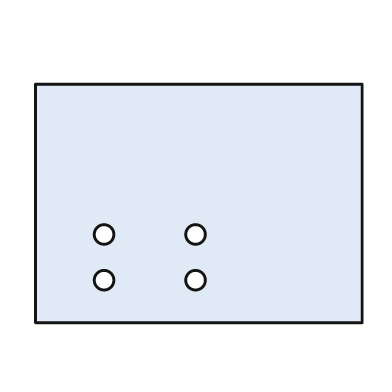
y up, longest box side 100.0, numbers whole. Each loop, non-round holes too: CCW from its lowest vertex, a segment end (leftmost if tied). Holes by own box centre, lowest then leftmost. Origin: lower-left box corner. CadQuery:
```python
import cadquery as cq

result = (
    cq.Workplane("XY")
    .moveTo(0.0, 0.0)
    .lineTo(100.0, 0.0)
    .lineTo(100.0, 73.0)
    .lineTo(0.0, 73.0)
    .close()
    .moveTo(21.0, 13.0)
    .circle(3.0)
    .moveTo(49.0, 13.0)
    .circle(3.0)
    .moveTo(21.0, 27.0)
    .circle(3.0)
    .moveTo(49.0, 27.0)
    .circle(3.0)
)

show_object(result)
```